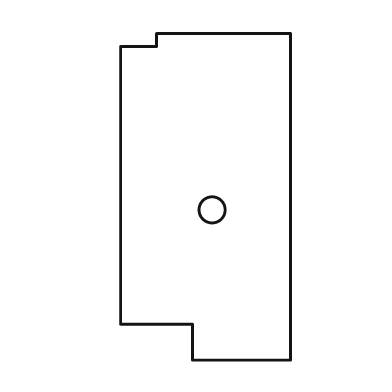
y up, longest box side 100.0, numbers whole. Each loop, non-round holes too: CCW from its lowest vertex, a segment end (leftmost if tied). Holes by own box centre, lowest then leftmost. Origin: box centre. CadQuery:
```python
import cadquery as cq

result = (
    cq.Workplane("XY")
    .moveTo(-4.0, -50.0)
    .lineTo(26.0, -50.0)
    .lineTo(26.0, 50.0)
    .lineTo(-15.0, 50.0)
    .lineTo(-15.0, 46.0)
    .lineTo(-26.0, 46.0)
    .lineTo(-26.0, -39.0)
    .lineTo(-4.0, -39.0)
    .close()
    .moveTo(2.0, -4.0)
    .circle(4.0)
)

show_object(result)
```